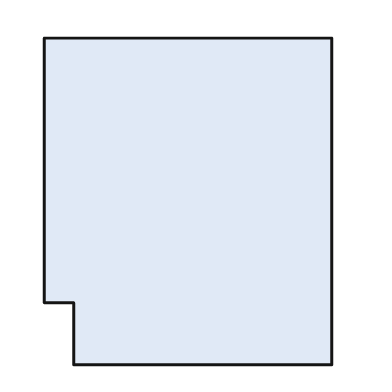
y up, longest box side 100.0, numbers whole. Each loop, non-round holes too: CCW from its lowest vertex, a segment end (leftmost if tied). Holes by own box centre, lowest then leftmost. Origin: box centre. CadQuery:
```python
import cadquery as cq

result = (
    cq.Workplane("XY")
    .moveTo(-35.0, -50.0)
    .lineTo(44.0, -50.0)
    .lineTo(44.0, 50.0)
    .lineTo(-44.0, 50.0)
    .lineTo(-44.0, -31.0)
    .lineTo(-35.0, -31.0)
    .close()
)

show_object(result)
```